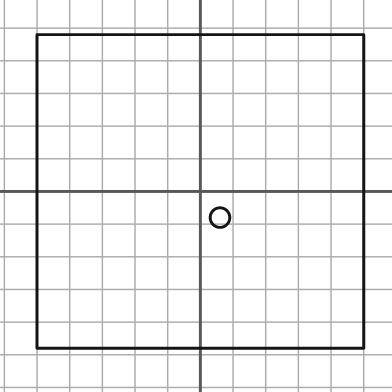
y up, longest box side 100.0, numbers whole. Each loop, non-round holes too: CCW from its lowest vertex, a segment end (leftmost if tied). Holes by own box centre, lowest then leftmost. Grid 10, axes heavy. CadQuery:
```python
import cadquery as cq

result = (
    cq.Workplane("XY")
    .moveTo(-50.0, -48.0)
    .lineTo(50.0, -48.0)
    .lineTo(50.0, 48.0)
    .lineTo(-50.0, 48.0)
    .close()
    .moveTo(6.0, -8.0)
    .circle(3.0)
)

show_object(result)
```